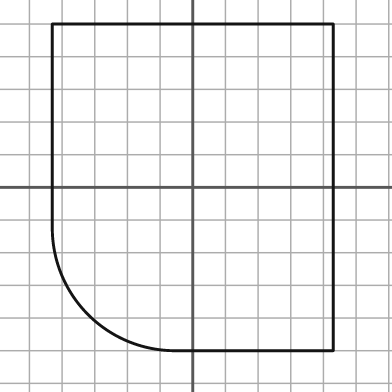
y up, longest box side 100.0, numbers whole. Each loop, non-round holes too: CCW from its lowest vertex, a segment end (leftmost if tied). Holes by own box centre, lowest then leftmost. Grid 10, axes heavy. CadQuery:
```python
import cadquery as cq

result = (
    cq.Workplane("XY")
    .moveTo(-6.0, -50.0)
    .lineTo(43.0, -50.0)
    .lineTo(43.0, 50.0)
    .lineTo(-43.0, 50.0)
    .lineTo(-43.0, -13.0)
    .threePointArc((-32.0, -39.0), (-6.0, -50.0))
    .close()
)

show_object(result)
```